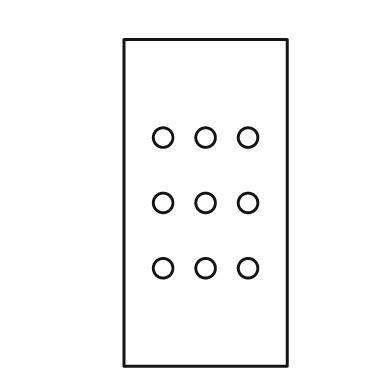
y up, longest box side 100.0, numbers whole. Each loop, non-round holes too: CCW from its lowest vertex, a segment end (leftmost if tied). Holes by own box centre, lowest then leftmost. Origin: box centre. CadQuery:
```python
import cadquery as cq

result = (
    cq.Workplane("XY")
    .moveTo(-25.0, -50.0)
    .lineTo(25.0, -50.0)
    .lineTo(25.0, 50.0)
    .lineTo(-25.0, 50.0)
    .close()
    .moveTo(-13.0, -20.0)
    .circle(3.0)
    .moveTo(0.0, -20.0)
    .circle(3.0)
    .moveTo(13.0, -20.0)
    .circle(3.0)
    .moveTo(-13.0, 0.0)
    .circle(3.0)
    .moveTo(0.0, 0.0)
    .circle(3.0)
    .moveTo(13.0, 0.0)
    .circle(3.0)
    .moveTo(-13.0, 20.0)
    .circle(3.0)
    .moveTo(0.0, 20.0)
    .circle(3.0)
    .moveTo(13.0, 20.0)
    .circle(3.0)
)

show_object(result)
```